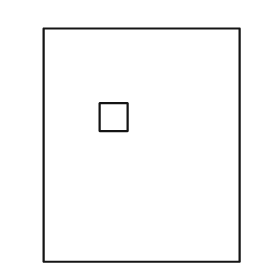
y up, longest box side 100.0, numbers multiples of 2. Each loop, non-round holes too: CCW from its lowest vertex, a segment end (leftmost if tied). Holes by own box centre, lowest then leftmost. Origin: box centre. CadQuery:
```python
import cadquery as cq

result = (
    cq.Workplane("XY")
    .moveTo(-42.0, -50.0)
    .lineTo(42.0, -50.0)
    .lineTo(42.0, 50.0)
    .lineTo(-42.0, 50.0)
    .close()
    .moveTo(-18.0, 6.0)
    .lineTo(-6.0, 6.0)
    .lineTo(-6.0, 18.0)
    .lineTo(-18.0, 18.0)
    .close()
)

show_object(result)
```